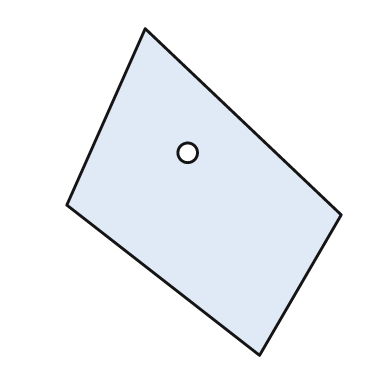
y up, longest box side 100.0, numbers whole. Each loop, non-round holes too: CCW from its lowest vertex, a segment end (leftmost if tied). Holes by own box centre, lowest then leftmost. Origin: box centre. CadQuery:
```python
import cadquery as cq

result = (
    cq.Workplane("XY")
    .moveTo(17.0, -50.0)
    .lineTo(42.0, -7.0)
    .lineTo(-18.0, 50.0)
    .lineTo(-42.0, -4.0)
    .close()
    .moveTo(-5.0, 12.0)
    .circle(3.0)
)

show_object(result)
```